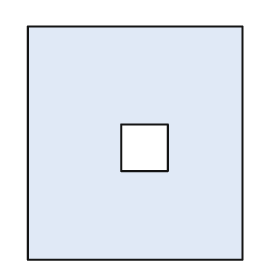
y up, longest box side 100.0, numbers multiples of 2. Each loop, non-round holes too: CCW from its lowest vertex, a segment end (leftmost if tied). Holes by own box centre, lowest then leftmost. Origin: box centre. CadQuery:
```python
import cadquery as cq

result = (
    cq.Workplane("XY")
    .moveTo(-46.0, -50.0)
    .lineTo(46.0, -50.0)
    .lineTo(46.0, 50.0)
    .lineTo(-46.0, 50.0)
    .close()
    .moveTo(-6.0, -12.0)
    .lineTo(14.0, -12.0)
    .lineTo(14.0, 8.0)
    .lineTo(-6.0, 8.0)
    .close()
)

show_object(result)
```